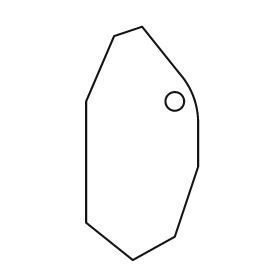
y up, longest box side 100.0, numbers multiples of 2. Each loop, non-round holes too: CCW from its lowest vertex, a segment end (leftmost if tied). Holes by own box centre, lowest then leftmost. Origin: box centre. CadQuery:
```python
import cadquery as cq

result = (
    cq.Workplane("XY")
    .moveTo(-4.0, -50.0)
    .lineTo(14.0, -40.0)
    .lineTo(24.0, -10.0)
    .lineTo(24.0, 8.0)
    .threePointArc((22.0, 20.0), (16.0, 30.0))
    .lineTo(0.0, 50.0)
    .lineTo(-12.0, 46.0)
    .lineTo(-24.0, 18.0)
    .lineTo(-24.0, -34.0)
    .close()
    .moveTo(14.0, 18.0)
    .circle(4.0)
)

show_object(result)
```